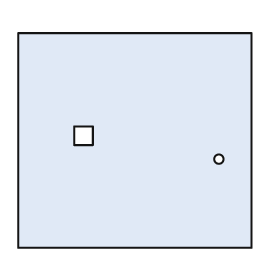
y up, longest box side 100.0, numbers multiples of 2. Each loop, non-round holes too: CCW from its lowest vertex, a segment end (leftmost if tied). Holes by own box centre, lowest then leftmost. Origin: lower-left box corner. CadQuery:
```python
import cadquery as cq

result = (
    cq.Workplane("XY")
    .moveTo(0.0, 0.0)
    .lineTo(100.0, 0.0)
    .lineTo(100.0, 92.0)
    .lineTo(0.0, 92.0)
    .close()
    .moveTo(86.0, 38.0)
    .circle(2.0)
    .moveTo(24.0, 44.0)
    .lineTo(32.0, 44.0)
    .lineTo(32.0, 52.0)
    .lineTo(24.0, 52.0)
    .close()
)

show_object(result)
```